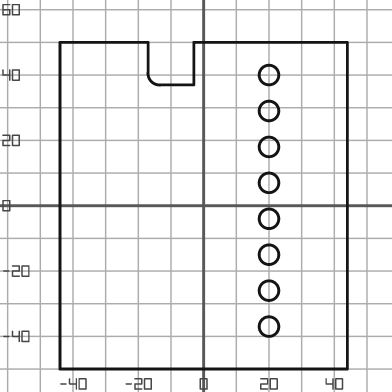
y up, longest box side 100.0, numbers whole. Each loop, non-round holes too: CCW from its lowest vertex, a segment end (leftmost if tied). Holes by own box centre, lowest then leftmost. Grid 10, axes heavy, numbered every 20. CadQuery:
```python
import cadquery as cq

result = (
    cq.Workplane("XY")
    .moveTo(-44.0, -50.0)
    .lineTo(44.0, -50.0)
    .lineTo(44.0, 50.0)
    .lineTo(-3.0, 50.0)
    .lineTo(-3.0, 37.0)
    .lineTo(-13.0, 37.0)
    .threePointArc((-16.0, 38.0), (-17.0, 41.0))
    .lineTo(-17.0, 50.0)
    .lineTo(-44.0, 50.0)
    .close()
    .moveTo(20.0, -37.0)
    .circle(3.0)
    .moveTo(20.0, -26.0)
    .circle(3.0)
    .moveTo(20.0, -15.0)
    .circle(3.0)
    .moveTo(20.0, -4.0)
    .circle(3.0)
    .moveTo(20.0, 7.0)
    .circle(3.0)
    .moveTo(20.0, 18.0)
    .circle(3.0)
    .moveTo(20.0, 29.0)
    .circle(3.0)
    .moveTo(20.0, 40.0)
    .circle(3.0)
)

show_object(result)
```